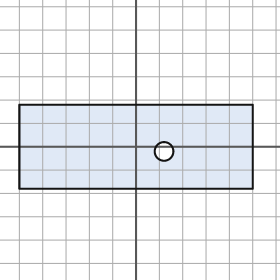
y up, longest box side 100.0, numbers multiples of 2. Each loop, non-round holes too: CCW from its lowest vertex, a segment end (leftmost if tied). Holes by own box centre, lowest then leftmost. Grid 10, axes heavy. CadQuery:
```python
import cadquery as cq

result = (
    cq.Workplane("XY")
    .moveTo(-50.0, -18.0)
    .lineTo(50.0, -18.0)
    .lineTo(50.0, 18.0)
    .lineTo(-50.0, 18.0)
    .close()
    .moveTo(12.0, -2.0)
    .circle(4.0)
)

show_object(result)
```